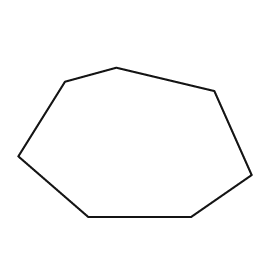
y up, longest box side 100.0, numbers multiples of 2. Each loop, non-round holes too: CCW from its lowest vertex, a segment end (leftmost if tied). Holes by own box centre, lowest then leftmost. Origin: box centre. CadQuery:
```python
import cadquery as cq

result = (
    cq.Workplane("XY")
    .moveTo(-20.0, -32.0)
    .lineTo(24.0, -32.0)
    .lineTo(50.0, -14.0)
    .lineTo(34.0, 22.0)
    .lineTo(-8.0, 32.0)
    .lineTo(-30.0, 26.0)
    .lineTo(-50.0, -6.0)
    .close()
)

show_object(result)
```